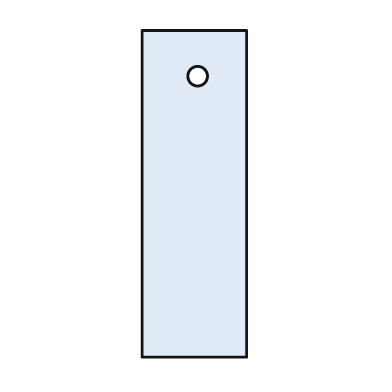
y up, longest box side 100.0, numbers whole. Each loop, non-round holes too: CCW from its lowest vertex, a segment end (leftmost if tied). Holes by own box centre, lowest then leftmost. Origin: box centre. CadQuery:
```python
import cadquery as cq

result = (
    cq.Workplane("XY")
    .moveTo(-16.0, -50.0)
    .lineTo(16.0, -50.0)
    .lineTo(16.0, 50.0)
    .lineTo(-16.0, 50.0)
    .close()
    .moveTo(1.0, 36.0)
    .circle(3.0)
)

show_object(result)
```